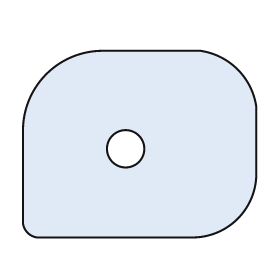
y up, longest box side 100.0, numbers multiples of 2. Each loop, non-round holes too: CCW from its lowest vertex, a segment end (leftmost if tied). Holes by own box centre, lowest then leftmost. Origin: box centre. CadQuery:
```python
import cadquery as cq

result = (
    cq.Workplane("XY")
    .moveTo(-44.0, -40.0)
    .lineTo(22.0, -40.0)
    .threePointArc((42.0, -32.0), (50.0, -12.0))
    .lineTo(50.0, 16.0)
    .threePointArc((42.0, 32.0), (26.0, 40.0))
    .lineTo(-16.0, 40.0)
    .threePointArc((-40.0, 30.0), (-50.0, 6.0))
    .lineTo(-50.0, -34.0)
    .threePointArc((-48.0, -38.0), (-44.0, -40.0))
    .close()
    .moveTo(-6.0, -2.0)
    .circle(8.0)
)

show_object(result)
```